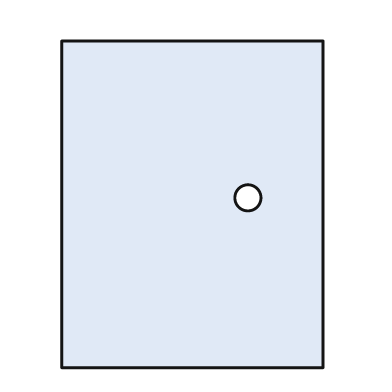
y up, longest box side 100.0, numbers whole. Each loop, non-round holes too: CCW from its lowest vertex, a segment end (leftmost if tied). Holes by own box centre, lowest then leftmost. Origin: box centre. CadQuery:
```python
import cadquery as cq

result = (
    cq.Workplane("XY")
    .moveTo(-40.0, -50.0)
    .lineTo(40.0, -50.0)
    .lineTo(40.0, 50.0)
    .lineTo(-40.0, 50.0)
    .close()
    .moveTo(17.0, 2.0)
    .circle(4.0)
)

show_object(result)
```